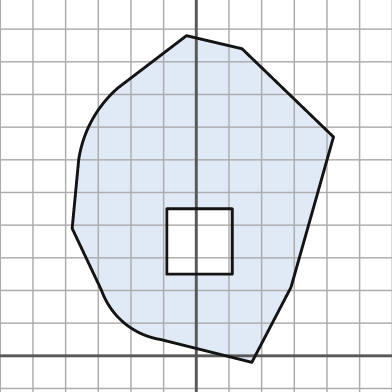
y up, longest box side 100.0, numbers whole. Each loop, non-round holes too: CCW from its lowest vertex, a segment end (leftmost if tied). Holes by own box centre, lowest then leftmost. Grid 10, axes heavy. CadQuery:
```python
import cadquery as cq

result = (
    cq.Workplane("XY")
    .moveTo(17.0, -2.0)
    .lineTo(29.0, 21.0)
    .lineTo(42.0, 67.0)
    .lineTo(14.0, 94.0)
    .lineTo(-3.0, 98.0)
    .lineTo(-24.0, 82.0)
    .threePointArc((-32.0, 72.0), (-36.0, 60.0))
    .lineTo(-38.0, 39.0)
    .lineTo(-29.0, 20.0)
    .threePointArc((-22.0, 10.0), (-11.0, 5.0))
    .close()
    .moveTo(-9.0, 25.0)
    .lineTo(11.0, 25.0)
    .lineTo(11.0, 45.0)
    .lineTo(-9.0, 45.0)
    .close()
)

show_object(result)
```